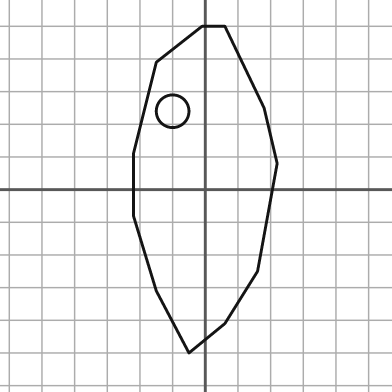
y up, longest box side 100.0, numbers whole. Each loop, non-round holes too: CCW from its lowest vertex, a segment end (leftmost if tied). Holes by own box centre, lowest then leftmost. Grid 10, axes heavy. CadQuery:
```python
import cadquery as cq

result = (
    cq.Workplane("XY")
    .moveTo(-5.0, -50.0)
    .lineTo(6.0, -41.0)
    .lineTo(16.0, -25.0)
    .lineTo(22.0, 8.0)
    .lineTo(18.0, 25.0)
    .lineTo(6.0, 50.0)
    .lineTo(-1.0, 50.0)
    .lineTo(-15.0, 39.0)
    .lineTo(-22.0, 11.0)
    .lineTo(-22.0, -8.0)
    .lineTo(-15.0, -31.0)
    .close()
    .moveTo(-10.0, 24.0)
    .circle(5.0)
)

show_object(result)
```